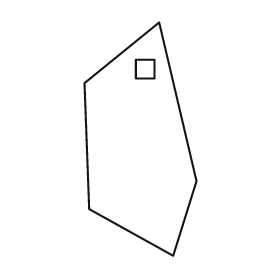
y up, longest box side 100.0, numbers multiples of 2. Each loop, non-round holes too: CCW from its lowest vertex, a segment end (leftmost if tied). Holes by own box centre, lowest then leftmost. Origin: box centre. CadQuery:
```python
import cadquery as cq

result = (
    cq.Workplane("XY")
    .moveTo(14.0, -50.0)
    .lineTo(24.0, -18.0)
    .lineTo(8.0, 50.0)
    .lineTo(-24.0, 24.0)
    .lineTo(-22.0, -30.0)
    .close()
    .moveTo(-2.0, 26.0)
    .lineTo(6.0, 26.0)
    .lineTo(6.0, 34.0)
    .lineTo(-2.0, 34.0)
    .close()
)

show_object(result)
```